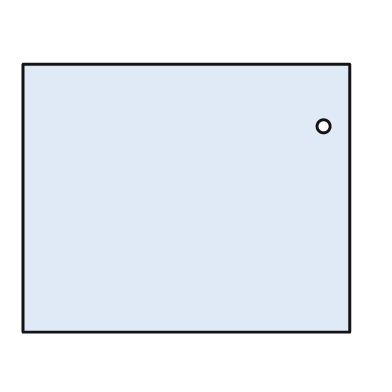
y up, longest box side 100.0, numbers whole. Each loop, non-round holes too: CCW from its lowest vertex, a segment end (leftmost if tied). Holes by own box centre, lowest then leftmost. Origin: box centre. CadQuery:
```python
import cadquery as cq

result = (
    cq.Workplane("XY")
    .moveTo(-50.0, -41.0)
    .lineTo(50.0, -41.0)
    .lineTo(50.0, 41.0)
    .lineTo(-50.0, 41.0)
    .close()
    .moveTo(42.0, 22.0)
    .circle(2.0)
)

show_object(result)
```